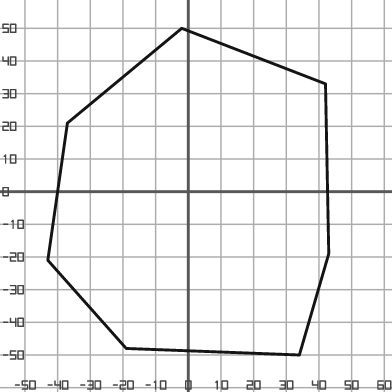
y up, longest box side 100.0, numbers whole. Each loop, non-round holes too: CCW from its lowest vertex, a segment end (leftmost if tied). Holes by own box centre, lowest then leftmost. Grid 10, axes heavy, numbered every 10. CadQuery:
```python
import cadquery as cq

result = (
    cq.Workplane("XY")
    .moveTo(34.0, -50.0)
    .lineTo(43.0, -19.0)
    .lineTo(42.0, 33.0)
    .lineTo(-2.0, 50.0)
    .lineTo(-37.0, 21.0)
    .lineTo(-43.0, -21.0)
    .lineTo(-19.0, -48.0)
    .close()
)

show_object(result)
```